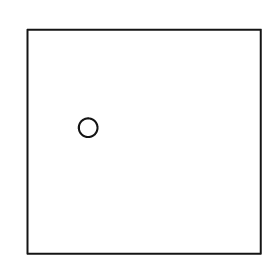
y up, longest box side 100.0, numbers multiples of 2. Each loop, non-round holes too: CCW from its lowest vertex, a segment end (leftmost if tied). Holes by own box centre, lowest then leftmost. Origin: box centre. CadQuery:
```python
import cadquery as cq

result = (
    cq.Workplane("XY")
    .moveTo(-50.0, -48.0)
    .lineTo(50.0, -48.0)
    .lineTo(50.0, 48.0)
    .lineTo(-50.0, 48.0)
    .close()
    .moveTo(-24.0, 6.0)
    .circle(4.0)
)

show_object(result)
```